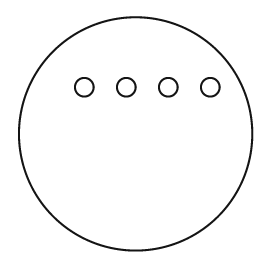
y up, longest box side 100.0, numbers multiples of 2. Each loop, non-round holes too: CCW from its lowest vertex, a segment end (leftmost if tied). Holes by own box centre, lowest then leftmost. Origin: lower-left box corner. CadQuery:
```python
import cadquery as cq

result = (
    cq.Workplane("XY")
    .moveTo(50.0, 50.0)
    .circle(50.0)
    .moveTo(28.0, 70.0)
    .circle(4.0)
    .moveTo(46.0, 70.0)
    .circle(4.0)
    .moveTo(64.0, 70.0)
    .circle(4.0)
    .moveTo(82.0, 70.0)
    .circle(4.0)
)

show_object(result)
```